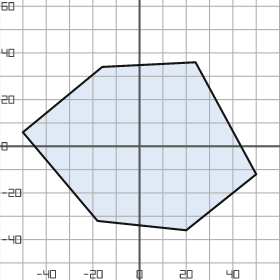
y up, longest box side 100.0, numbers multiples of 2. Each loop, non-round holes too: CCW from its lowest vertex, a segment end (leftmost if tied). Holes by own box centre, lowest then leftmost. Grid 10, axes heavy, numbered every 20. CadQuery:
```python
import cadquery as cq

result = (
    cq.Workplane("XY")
    .moveTo(20.0, -36.0)
    .lineTo(50.0, -12.0)
    .lineTo(24.0, 36.0)
    .lineTo(-16.0, 34.0)
    .lineTo(-50.0, 6.0)
    .lineTo(-18.0, -32.0)
    .close()
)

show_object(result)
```